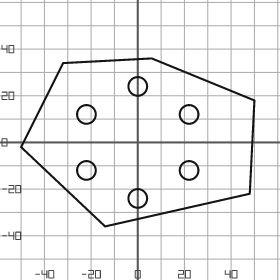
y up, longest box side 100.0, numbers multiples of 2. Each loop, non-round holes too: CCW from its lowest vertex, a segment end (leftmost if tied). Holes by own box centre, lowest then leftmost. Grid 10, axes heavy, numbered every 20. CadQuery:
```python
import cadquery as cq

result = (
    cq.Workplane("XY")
    .moveTo(-14.0, -36.0)
    .lineTo(48.0, -22.0)
    .lineTo(50.0, 18.0)
    .lineTo(6.0, 36.0)
    .lineTo(-32.0, 34.0)
    .lineTo(-50.0, -2.0)
    .close()
    .moveTo(0.0, -24.0)
    .circle(4.0)
    .moveTo(-22.0, -12.0)
    .circle(4.0)
    .moveTo(22.0, -12.0)
    .circle(4.0)
    .moveTo(-22.0, 12.0)
    .circle(4.0)
    .moveTo(22.0, 12.0)
    .circle(4.0)
    .moveTo(0.0, 24.0)
    .circle(4.0)
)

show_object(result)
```